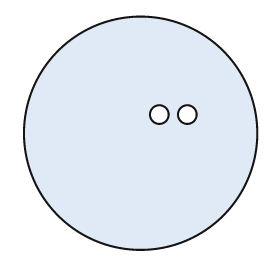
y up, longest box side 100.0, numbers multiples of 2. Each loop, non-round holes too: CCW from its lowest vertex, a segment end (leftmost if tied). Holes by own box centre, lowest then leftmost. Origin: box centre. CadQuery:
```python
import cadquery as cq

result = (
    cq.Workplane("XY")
    .moveTo(0.0, 0.0)
    .circle(50.0)
    .moveTo(8.0, 8.0)
    .circle(4.0)
    .moveTo(20.0, 8.0)
    .circle(4.0)
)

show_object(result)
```